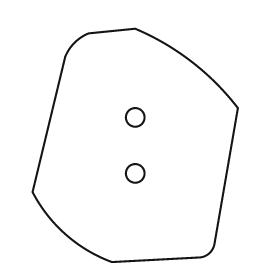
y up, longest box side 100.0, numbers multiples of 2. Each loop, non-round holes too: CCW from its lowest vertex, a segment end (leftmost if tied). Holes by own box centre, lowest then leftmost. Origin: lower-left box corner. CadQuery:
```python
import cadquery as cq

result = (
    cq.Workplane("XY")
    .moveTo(34.0, 0.0)
    .lineTo(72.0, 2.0)
    .threePointArc((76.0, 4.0), (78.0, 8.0))
    .lineTo(88.0, 66.0)
    .threePointArc((68.0, 86.0), (44.0, 100.0))
    .lineTo(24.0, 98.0)
    .threePointArc((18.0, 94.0), (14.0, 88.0))
    .lineTo(0.0, 30.0)
    .threePointArc((14.0, 12.0), (34.0, 0.0))
    .close()
    .moveTo(44.0, 38.0)
    .circle(4.0)
    .moveTo(44.0, 62.0)
    .circle(4.0)
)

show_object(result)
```